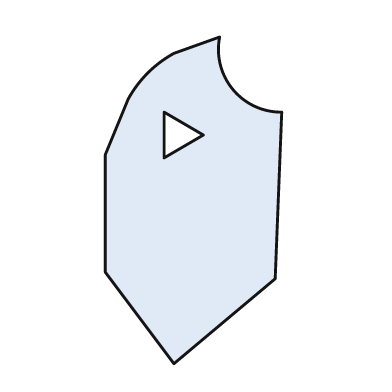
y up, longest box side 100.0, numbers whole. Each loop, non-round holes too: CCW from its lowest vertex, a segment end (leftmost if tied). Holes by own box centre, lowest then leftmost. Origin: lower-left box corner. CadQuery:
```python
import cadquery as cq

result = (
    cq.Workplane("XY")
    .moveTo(21.0, 0.0)
    .lineTo(52.0, 26.0)
    .lineTo(54.0, 77.0)
    .threePointArc((39.0, 84.0), (35.0, 100.0))
    .lineTo(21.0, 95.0)
    .threePointArc((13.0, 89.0), (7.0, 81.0))
    .lineTo(0.0, 64.0)
    .lineTo(0.0, 28.0)
    .close()
    .moveTo(18.0, 63.0)
    .lineTo(30.0, 70.0)
    .lineTo(18.0, 77.0)
    .close()
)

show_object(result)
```